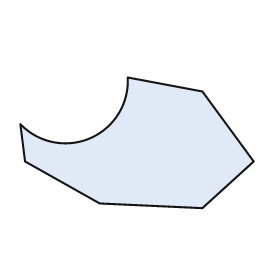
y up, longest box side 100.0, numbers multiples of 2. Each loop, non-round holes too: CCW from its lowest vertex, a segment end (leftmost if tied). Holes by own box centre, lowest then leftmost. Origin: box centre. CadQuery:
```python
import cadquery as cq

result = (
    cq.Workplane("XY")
    .moveTo(28.0, -28.0)
    .lineTo(50.0, -8.0)
    .lineTo(28.0, 22.0)
    .lineTo(-4.0, 28.0)
    .threePointArc((-20.0, 2.0), (-50.0, 8.0))
    .lineTo(-48.0, -8.0)
    .lineTo(-16.0, -26.0)
    .close()
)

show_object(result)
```